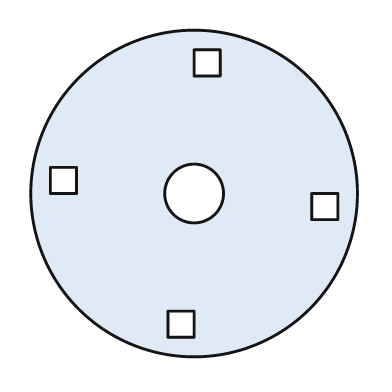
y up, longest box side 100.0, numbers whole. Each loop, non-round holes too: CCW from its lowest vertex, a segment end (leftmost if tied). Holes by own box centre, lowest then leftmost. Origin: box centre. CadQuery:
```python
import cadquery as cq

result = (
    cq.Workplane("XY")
    .moveTo(0.0, 0.0)
    .circle(50.0)
    .moveTo(-8.0, -44.0)
    .lineTo(0.0, -44.0)
    .lineTo(0.0, -36.0)
    .lineTo(-8.0, -36.0)
    .close()
    .moveTo(36.0, -8.0)
    .lineTo(44.0, -8.0)
    .lineTo(44.0, 0.0)
    .lineTo(36.0, 0.0)
    .close()
    .moveTo(0.0, 0.0)
    .circle(9.0)
    .moveTo(-44.0, 0.0)
    .lineTo(-36.0, 0.0)
    .lineTo(-36.0, 8.0)
    .lineTo(-44.0, 8.0)
    .close()
    .moveTo(0.0, 36.0)
    .lineTo(8.0, 36.0)
    .lineTo(8.0, 44.0)
    .lineTo(0.0, 44.0)
    .close()
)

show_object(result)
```